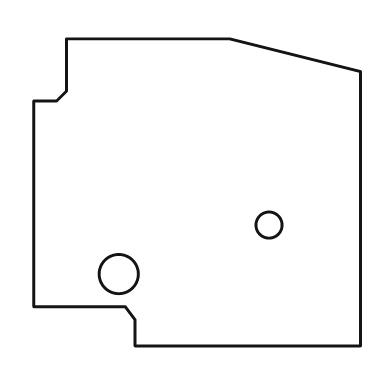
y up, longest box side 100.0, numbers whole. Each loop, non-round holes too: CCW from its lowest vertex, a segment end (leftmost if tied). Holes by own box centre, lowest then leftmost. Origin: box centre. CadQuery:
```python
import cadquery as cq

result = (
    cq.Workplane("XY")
    .moveTo(-19.0, -47.0)
    .lineTo(50.0, -47.0)
    .lineTo(50.0, 37.0)
    .lineTo(10.0, 47.0)
    .lineTo(-40.0, 47.0)
    .lineTo(-40.0, 31.0)
    .lineTo(-43.0, 28.0)
    .lineTo(-50.0, 28.0)
    .lineTo(-50.0, -35.0)
    .lineTo(-22.0, -35.0)
    .lineTo(-19.0, -39.0)
    .close()
    .moveTo(-24.0, -25.0)
    .circle(6.0)
    .moveTo(22.0, -10.0)
    .circle(4.0)
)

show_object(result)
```